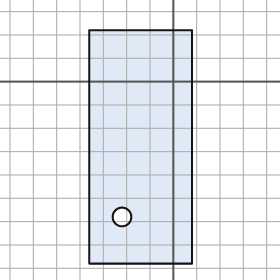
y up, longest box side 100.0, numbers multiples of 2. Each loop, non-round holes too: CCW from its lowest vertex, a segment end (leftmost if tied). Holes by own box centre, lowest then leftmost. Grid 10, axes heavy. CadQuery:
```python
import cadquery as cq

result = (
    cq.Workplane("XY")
    .moveTo(-36.0, -78.0)
    .lineTo(8.0, -78.0)
    .lineTo(8.0, 22.0)
    .lineTo(-36.0, 22.0)
    .close()
    .moveTo(-22.0, -58.0)
    .circle(4.0)
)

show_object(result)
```